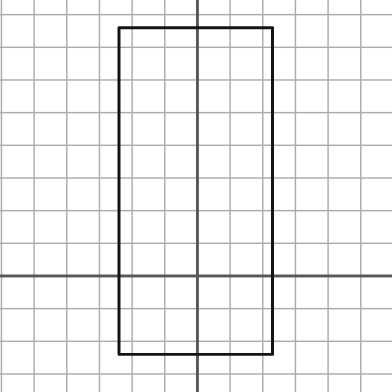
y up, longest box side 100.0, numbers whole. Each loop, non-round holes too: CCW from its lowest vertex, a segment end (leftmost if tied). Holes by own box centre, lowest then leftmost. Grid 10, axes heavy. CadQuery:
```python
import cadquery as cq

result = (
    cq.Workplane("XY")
    .moveTo(-24.0, -24.0)
    .lineTo(23.0, -24.0)
    .lineTo(23.0, 76.0)
    .lineTo(-24.0, 76.0)
    .close()
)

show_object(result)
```